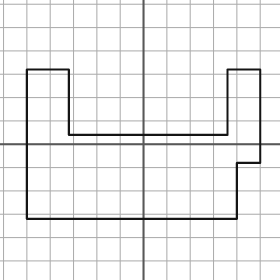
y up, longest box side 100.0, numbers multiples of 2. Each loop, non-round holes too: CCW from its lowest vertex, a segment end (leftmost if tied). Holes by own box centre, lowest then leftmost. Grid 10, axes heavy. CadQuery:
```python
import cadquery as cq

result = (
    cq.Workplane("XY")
    .moveTo(-50.0, -32.0)
    .lineTo(40.0, -32.0)
    .lineTo(40.0, -8.0)
    .lineTo(50.0, -8.0)
    .lineTo(50.0, 32.0)
    .lineTo(36.0, 32.0)
    .lineTo(36.0, 4.0)
    .lineTo(-32.0, 4.0)
    .lineTo(-32.0, 32.0)
    .lineTo(-50.0, 32.0)
    .close()
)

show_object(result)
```